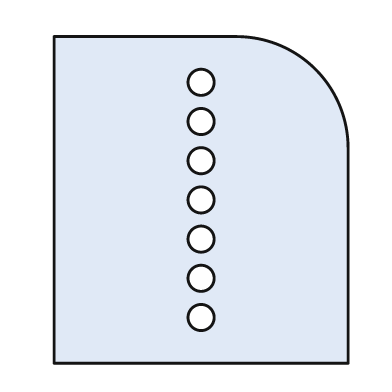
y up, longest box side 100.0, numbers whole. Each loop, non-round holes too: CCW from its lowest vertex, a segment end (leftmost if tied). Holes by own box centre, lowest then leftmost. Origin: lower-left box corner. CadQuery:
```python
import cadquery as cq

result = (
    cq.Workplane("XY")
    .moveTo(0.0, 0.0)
    .lineTo(90.0, 0.0)
    .lineTo(90.0, 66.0)
    .threePointArc((80.0, 90.0), (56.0, 100.0))
    .lineTo(0.0, 100.0)
    .close()
    .moveTo(45.0, 14.0)
    .circle(4.0)
    .moveTo(45.0, 26.0)
    .circle(4.0)
    .moveTo(45.0, 38.0)
    .circle(4.0)
    .moveTo(45.0, 50.0)
    .circle(4.0)
    .moveTo(45.0, 62.0)
    .circle(4.0)
    .moveTo(45.0, 74.0)
    .circle(4.0)
    .moveTo(45.0, 86.0)
    .circle(4.0)
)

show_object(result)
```